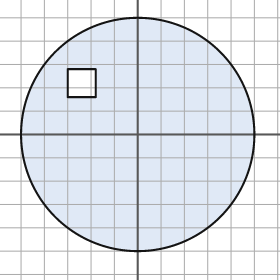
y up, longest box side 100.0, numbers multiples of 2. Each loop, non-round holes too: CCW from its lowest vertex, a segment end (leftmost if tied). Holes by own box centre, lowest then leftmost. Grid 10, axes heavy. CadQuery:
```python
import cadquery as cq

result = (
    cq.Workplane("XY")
    .moveTo(0.0, 0.0)
    .circle(50.0)
    .moveTo(-30.0, 16.0)
    .lineTo(-18.0, 16.0)
    .lineTo(-18.0, 28.0)
    .lineTo(-30.0, 28.0)
    .close()
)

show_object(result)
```